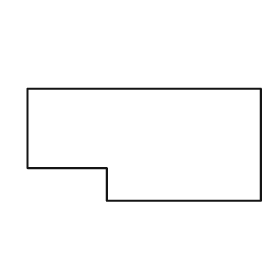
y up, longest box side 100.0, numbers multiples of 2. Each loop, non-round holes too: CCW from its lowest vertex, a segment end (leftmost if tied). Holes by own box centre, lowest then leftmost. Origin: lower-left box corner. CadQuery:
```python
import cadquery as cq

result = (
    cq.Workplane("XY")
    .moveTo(34.0, 0.0)
    .lineTo(100.0, 0.0)
    .lineTo(100.0, 48.0)
    .lineTo(0.0, 48.0)
    .lineTo(0.0, 14.0)
    .lineTo(34.0, 14.0)
    .close()
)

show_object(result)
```